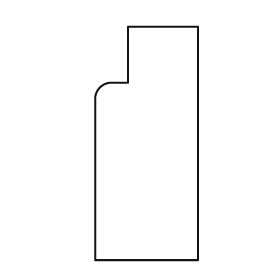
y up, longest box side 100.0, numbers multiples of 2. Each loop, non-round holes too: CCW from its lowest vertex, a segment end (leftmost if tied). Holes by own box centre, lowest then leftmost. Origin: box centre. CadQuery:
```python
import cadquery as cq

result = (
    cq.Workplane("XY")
    .moveTo(-22.0, -50.0)
    .lineTo(22.0, -50.0)
    .lineTo(22.0, 50.0)
    .lineTo(-8.0, 50.0)
    .lineTo(-8.0, 26.0)
    .lineTo(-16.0, 26.0)
    .threePointArc((-20.0, 24.0), (-22.0, 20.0))
    .close()
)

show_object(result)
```